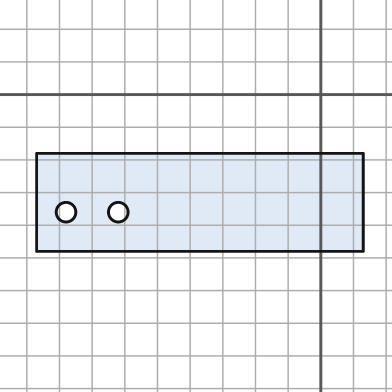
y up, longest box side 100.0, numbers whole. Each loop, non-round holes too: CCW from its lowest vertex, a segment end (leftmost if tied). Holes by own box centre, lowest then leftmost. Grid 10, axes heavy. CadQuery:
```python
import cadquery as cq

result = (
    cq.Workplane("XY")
    .moveTo(-87.0, -48.0)
    .lineTo(13.0, -48.0)
    .lineTo(13.0, -18.0)
    .lineTo(-87.0, -18.0)
    .close()
    .moveTo(-78.0, -36.0)
    .circle(3.0)
    .moveTo(-62.0, -36.0)
    .circle(3.0)
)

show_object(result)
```